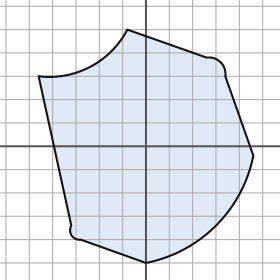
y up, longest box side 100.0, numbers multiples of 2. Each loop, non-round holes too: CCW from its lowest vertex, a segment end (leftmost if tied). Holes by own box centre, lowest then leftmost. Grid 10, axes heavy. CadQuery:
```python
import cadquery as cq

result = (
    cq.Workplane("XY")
    .moveTo(0.0, -50.0)
    .threePointArc((30.0, -34.0), (46.0, -4.0))
    .lineTo(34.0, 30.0)
    .threePointArc((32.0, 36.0), (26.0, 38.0))
    .lineTo(-8.0, 50.0)
    .threePointArc((-24.0, 34.0), (-46.0, 30.0))
    .lineTo(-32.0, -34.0)
    .threePointArc((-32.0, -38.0), (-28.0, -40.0))
    .close()
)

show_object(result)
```